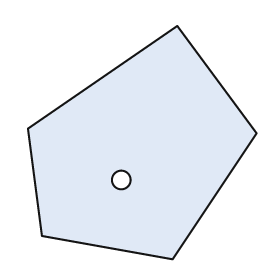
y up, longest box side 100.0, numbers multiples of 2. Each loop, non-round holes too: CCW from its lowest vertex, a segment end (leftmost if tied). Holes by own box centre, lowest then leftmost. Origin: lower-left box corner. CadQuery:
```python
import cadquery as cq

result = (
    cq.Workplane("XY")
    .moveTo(62.0, 0.0)
    .lineTo(98.0, 54.0)
    .lineTo(64.0, 100.0)
    .lineTo(0.0, 56.0)
    .lineTo(6.0, 10.0)
    .close()
    .moveTo(40.0, 34.0)
    .circle(4.0)
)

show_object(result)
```